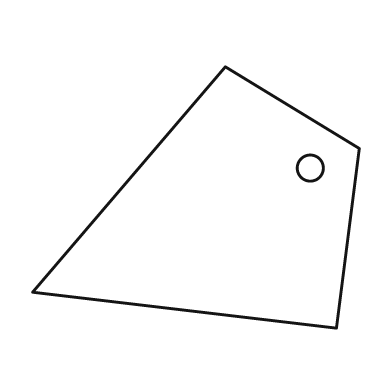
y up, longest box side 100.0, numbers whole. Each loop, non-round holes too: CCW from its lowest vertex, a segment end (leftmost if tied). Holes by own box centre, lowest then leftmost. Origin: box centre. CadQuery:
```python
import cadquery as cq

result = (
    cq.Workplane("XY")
    .moveTo(43.0, -40.0)
    .lineTo(50.0, 15.0)
    .lineTo(9.0, 40.0)
    .lineTo(-50.0, -29.0)
    .close()
    .moveTo(35.0, 9.0)
    .circle(4.0)
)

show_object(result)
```